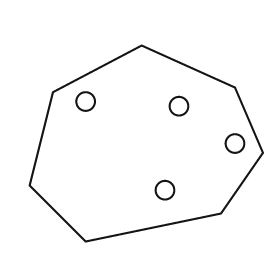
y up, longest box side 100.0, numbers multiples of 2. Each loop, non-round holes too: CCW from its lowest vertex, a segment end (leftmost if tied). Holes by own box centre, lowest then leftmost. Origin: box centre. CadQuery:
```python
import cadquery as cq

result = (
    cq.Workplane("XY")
    .moveTo(-26.0, -42.0)
    .lineTo(32.0, -30.0)
    .lineTo(50.0, -4.0)
    .lineTo(38.0, 24.0)
    .lineTo(-2.0, 42.0)
    .lineTo(-40.0, 22.0)
    .lineTo(-50.0, -18.0)
    .close()
    .moveTo(8.0, -20.0)
    .circle(4.0)
    .moveTo(38.0, 0.0)
    .circle(4.0)
    .moveTo(14.0, 16.0)
    .circle(4.0)
    .moveTo(-26.0, 18.0)
    .circle(4.0)
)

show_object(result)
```